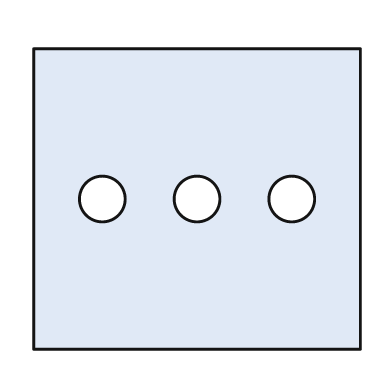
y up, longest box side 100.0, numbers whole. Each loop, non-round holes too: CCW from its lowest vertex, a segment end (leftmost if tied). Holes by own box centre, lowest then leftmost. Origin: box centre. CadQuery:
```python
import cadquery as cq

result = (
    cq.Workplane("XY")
    .moveTo(-50.0, -46.0)
    .lineTo(50.0, -46.0)
    .lineTo(50.0, 46.0)
    .lineTo(-50.0, 46.0)
    .close()
    .moveTo(-29.0, 0.0)
    .circle(7.0)
    .moveTo(0.0, 0.0)
    .circle(7.0)
    .moveTo(29.0, 0.0)
    .circle(7.0)
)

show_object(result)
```